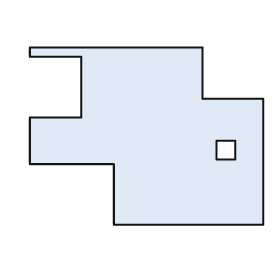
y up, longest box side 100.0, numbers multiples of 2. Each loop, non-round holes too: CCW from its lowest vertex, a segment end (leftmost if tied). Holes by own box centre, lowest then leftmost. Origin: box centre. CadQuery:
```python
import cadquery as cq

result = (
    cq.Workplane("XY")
    .moveTo(-14.0, -38.0)
    .lineTo(50.0, -38.0)
    .lineTo(50.0, 16.0)
    .lineTo(24.0, 16.0)
    .lineTo(24.0, 38.0)
    .lineTo(-50.0, 38.0)
    .lineTo(-50.0, 34.0)
    .lineTo(-28.0, 34.0)
    .lineTo(-28.0, 8.0)
    .lineTo(-50.0, 8.0)
    .lineTo(-50.0, -12.0)
    .lineTo(-14.0, -12.0)
    .close()
    .moveTo(30.0, -10.0)
    .lineTo(38.0, -10.0)
    .lineTo(38.0, -2.0)
    .lineTo(30.0, -2.0)
    .close()
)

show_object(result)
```